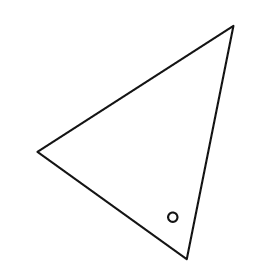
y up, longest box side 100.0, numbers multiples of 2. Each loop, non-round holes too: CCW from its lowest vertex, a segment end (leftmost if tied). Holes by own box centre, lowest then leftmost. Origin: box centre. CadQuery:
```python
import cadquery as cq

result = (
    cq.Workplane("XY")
    .moveTo(22.0, -50.0)
    .lineTo(42.0, 50.0)
    .lineTo(-42.0, -4.0)
    .close()
    .moveTo(16.0, -32.0)
    .circle(2.0)
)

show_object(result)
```